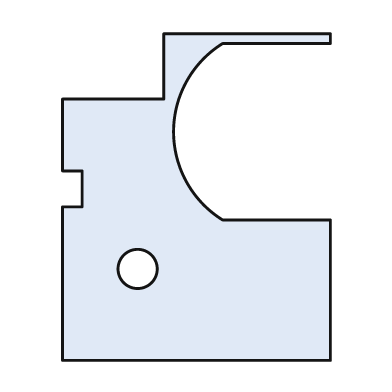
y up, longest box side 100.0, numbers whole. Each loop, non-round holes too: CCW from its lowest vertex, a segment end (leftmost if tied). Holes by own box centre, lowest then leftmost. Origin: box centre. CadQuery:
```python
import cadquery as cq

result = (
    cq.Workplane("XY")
    .moveTo(-41.0, -50.0)
    .lineTo(41.0, -50.0)
    .lineTo(41.0, -7.0)
    .lineTo(8.0, -7.0)
    .threePointArc((-7.0, 20.0), (8.0, 47.0))
    .lineTo(41.0, 47.0)
    .lineTo(41.0, 50.0)
    .lineTo(-10.0, 50.0)
    .lineTo(-10.0, 30.0)
    .lineTo(-41.0, 30.0)
    .lineTo(-41.0, 8.0)
    .lineTo(-35.0, 8.0)
    .lineTo(-35.0, -3.0)
    .lineTo(-41.0, -3.0)
    .close()
    .moveTo(-18.0, -22.0)
    .circle(6.0)
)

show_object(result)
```